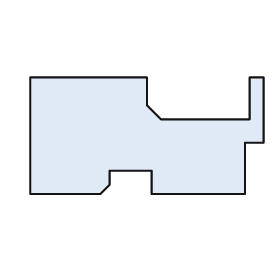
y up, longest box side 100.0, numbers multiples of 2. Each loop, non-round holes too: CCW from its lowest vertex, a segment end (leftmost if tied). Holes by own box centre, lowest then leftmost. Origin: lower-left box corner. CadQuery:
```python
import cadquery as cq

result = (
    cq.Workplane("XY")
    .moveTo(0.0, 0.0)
    .lineTo(30.0, 0.0)
    .lineTo(34.0, 4.0)
    .lineTo(34.0, 10.0)
    .lineTo(52.0, 10.0)
    .lineTo(52.0, 0.0)
    .lineTo(92.0, 0.0)
    .lineTo(92.0, 22.0)
    .lineTo(100.0, 22.0)
    .lineTo(100.0, 50.0)
    .lineTo(94.0, 50.0)
    .lineTo(94.0, 32.0)
    .lineTo(56.0, 32.0)
    .lineTo(50.0, 38.0)
    .lineTo(50.0, 50.0)
    .lineTo(0.0, 50.0)
    .close()
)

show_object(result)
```